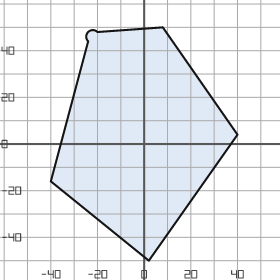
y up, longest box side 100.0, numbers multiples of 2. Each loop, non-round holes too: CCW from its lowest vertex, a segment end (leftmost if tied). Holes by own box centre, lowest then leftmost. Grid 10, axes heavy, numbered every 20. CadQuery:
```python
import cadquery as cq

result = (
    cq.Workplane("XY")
    .moveTo(2.0, -50.0)
    .lineTo(40.0, 4.0)
    .lineTo(8.0, 50.0)
    .lineTo(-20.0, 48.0)
    .threePointArc((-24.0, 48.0), (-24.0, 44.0))
    .lineTo(-40.0, -16.0)
    .close()
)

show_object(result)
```